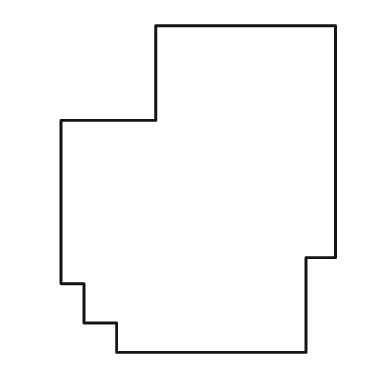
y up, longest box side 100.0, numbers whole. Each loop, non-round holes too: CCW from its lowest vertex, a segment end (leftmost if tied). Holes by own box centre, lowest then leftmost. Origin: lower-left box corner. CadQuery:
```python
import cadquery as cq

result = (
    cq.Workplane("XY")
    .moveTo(17.0, 0.0)
    .lineTo(75.0, 0.0)
    .lineTo(75.0, 29.0)
    .lineTo(84.0, 29.0)
    .lineTo(84.0, 100.0)
    .lineTo(29.0, 100.0)
    .lineTo(29.0, 71.0)
    .lineTo(0.0, 71.0)
    .lineTo(0.0, 21.0)
    .lineTo(7.0, 21.0)
    .lineTo(7.0, 9.0)
    .lineTo(17.0, 9.0)
    .close()
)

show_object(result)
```